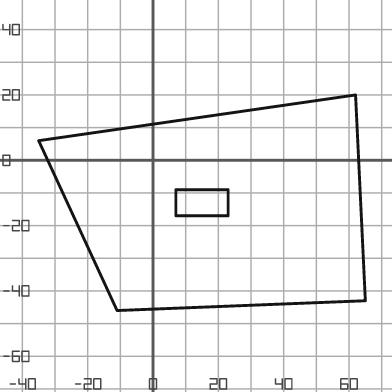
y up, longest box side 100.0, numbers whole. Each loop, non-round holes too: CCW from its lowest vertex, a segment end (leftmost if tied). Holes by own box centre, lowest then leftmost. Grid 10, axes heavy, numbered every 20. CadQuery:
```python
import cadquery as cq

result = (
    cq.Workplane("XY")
    .moveTo(-11.0, -46.0)
    .lineTo(65.0, -43.0)
    .lineTo(62.0, 20.0)
    .lineTo(-35.0, 6.0)
    .close()
    .moveTo(7.0, -17.0)
    .lineTo(23.0, -17.0)
    .lineTo(23.0, -9.0)
    .lineTo(7.0, -9.0)
    .close()
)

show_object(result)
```